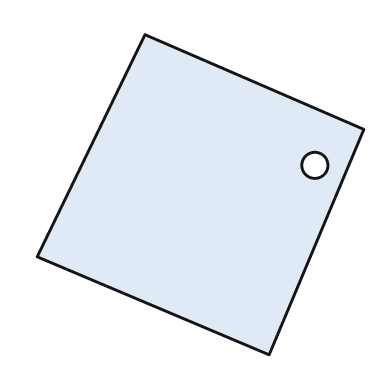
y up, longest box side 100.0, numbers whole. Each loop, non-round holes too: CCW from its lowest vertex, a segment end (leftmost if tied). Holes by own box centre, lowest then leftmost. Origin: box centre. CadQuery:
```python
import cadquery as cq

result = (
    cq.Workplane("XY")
    .moveTo(21.0, -49.0)
    .lineTo(50.0, 20.0)
    .lineTo(-17.0, 49.0)
    .lineTo(-50.0, -19.0)
    .close()
    .moveTo(35.0, 9.0)
    .circle(4.0)
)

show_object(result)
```